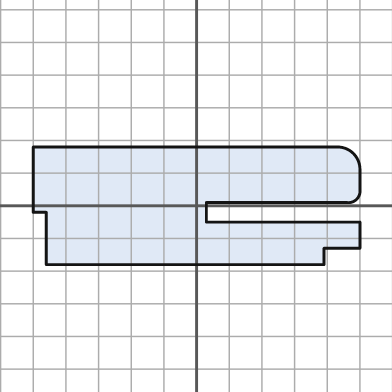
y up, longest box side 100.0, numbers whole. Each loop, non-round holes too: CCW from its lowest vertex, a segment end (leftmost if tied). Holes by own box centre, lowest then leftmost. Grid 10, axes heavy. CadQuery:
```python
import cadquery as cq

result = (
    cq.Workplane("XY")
    .moveTo(-46.0, -18.0)
    .lineTo(39.0, -18.0)
    .lineTo(39.0, -13.0)
    .lineTo(50.0, -13.0)
    .lineTo(50.0, -5.0)
    .lineTo(3.0, -5.0)
    .lineTo(3.0, 1.0)
    .lineTo(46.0, 1.0)
    .threePointArc((49.0, 2.0), (50.0, 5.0))
    .lineTo(50.0, 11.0)
    .threePointArc((48.0, 16.0), (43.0, 18.0))
    .lineTo(-50.0, 18.0)
    .lineTo(-50.0, -2.0)
    .lineTo(-46.0, -2.0)
    .close()
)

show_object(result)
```